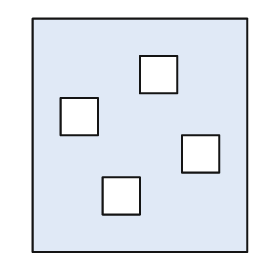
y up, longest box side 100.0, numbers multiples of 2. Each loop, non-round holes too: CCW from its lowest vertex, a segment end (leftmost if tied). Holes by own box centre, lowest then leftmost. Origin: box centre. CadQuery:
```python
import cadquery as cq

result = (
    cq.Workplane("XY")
    .moveTo(-46.0, -50.0)
    .lineTo(46.0, -50.0)
    .lineTo(46.0, 50.0)
    .lineTo(-46.0, 50.0)
    .close()
    .moveTo(-16.0, -34.0)
    .lineTo(0.0, -34.0)
    .lineTo(0.0, -18.0)
    .lineTo(-16.0, -18.0)
    .close()
    .moveTo(18.0, -16.0)
    .lineTo(34.0, -16.0)
    .lineTo(34.0, 0.0)
    .lineTo(18.0, 0.0)
    .close()
    .moveTo(-34.0, 0.0)
    .lineTo(-18.0, 0.0)
    .lineTo(-18.0, 16.0)
    .lineTo(-34.0, 16.0)
    .close()
    .moveTo(0.0, 18.0)
    .lineTo(16.0, 18.0)
    .lineTo(16.0, 34.0)
    .lineTo(0.0, 34.0)
    .close()
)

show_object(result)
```